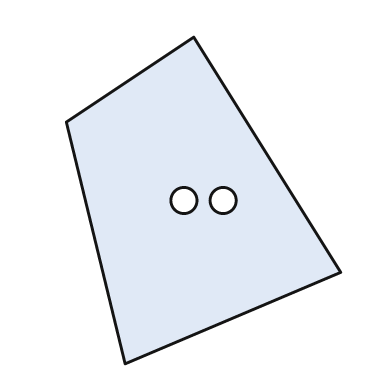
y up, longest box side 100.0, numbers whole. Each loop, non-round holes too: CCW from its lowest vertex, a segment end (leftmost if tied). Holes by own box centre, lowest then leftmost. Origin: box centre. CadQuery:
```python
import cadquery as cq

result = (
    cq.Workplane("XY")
    .moveTo(-24.0, -50.0)
    .lineTo(42.0, -22.0)
    .lineTo(-3.0, 50.0)
    .lineTo(-42.0, 24.0)
    .close()
    .moveTo(-6.0, 0.0)
    .circle(4.0)
    .moveTo(6.0, 0.0)
    .circle(4.0)
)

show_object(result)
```